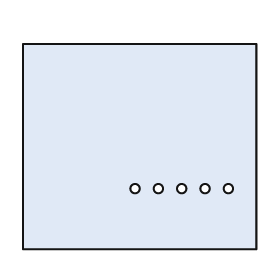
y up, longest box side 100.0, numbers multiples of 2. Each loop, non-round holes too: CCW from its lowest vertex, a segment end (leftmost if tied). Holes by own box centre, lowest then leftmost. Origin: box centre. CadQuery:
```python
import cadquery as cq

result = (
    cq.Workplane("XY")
    .moveTo(-50.0, -44.0)
    .lineTo(50.0, -44.0)
    .lineTo(50.0, 44.0)
    .lineTo(-50.0, 44.0)
    .close()
    .moveTo(-2.0, -18.0)
    .circle(2.0)
    .moveTo(8.0, -18.0)
    .circle(2.0)
    .moveTo(18.0, -18.0)
    .circle(2.0)
    .moveTo(28.0, -18.0)
    .circle(2.0)
    .moveTo(38.0, -18.0)
    .circle(2.0)
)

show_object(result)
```